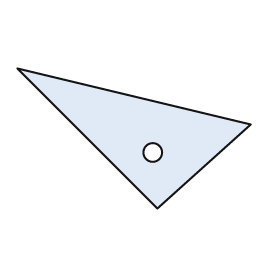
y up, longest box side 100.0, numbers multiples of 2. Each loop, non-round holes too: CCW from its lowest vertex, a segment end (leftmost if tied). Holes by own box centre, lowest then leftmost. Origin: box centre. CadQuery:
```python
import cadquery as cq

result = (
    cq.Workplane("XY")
    .moveTo(10.0, -30.0)
    .lineTo(50.0, 6.0)
    .lineTo(-50.0, 30.0)
    .close()
    .moveTo(8.0, -6.0)
    .circle(4.0)
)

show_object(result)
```